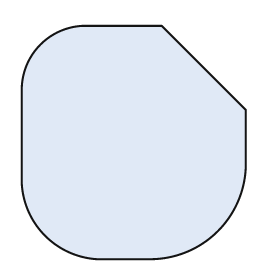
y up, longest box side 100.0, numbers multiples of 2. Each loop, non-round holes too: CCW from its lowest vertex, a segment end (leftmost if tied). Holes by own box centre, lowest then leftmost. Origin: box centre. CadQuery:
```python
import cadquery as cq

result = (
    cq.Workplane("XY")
    .moveTo(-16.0, -50.0)
    .lineTo(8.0, -50.0)
    .threePointArc((36.0, -38.0), (48.0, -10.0))
    .lineTo(48.0, 14.0)
    .lineTo(12.0, 50.0)
    .lineTo(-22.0, 50.0)
    .threePointArc((-40.0, 42.0), (-48.0, 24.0))
    .lineTo(-48.0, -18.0)
    .threePointArc((-38.0, -40.0), (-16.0, -50.0))
    .close()
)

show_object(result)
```